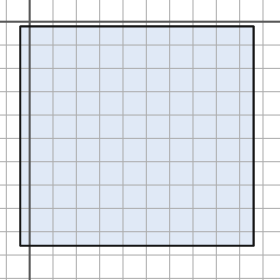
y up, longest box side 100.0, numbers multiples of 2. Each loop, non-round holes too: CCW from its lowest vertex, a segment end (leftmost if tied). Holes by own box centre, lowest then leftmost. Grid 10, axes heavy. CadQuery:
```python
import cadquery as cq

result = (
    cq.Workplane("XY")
    .moveTo(-4.0, -96.0)
    .lineTo(96.0, -96.0)
    .lineTo(96.0, -2.0)
    .lineTo(-4.0, -2.0)
    .close()
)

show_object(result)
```